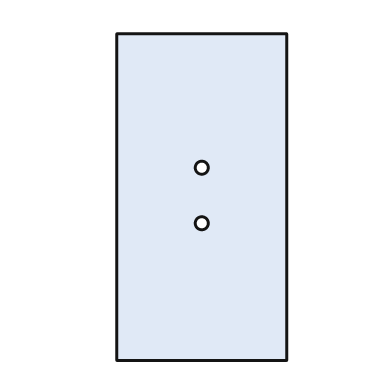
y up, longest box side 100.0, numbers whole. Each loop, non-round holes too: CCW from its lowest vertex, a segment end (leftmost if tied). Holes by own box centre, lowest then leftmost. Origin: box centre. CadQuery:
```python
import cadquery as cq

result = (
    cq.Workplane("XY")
    .moveTo(-26.0, -50.0)
    .lineTo(26.0, -50.0)
    .lineTo(26.0, 50.0)
    .lineTo(-26.0, 50.0)
    .close()
    .moveTo(0.0, -8.0)
    .circle(2.0)
    .moveTo(0.0, 9.0)
    .circle(2.0)
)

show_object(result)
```